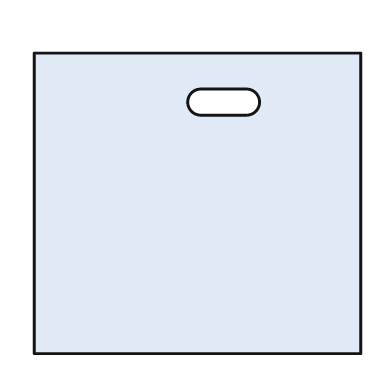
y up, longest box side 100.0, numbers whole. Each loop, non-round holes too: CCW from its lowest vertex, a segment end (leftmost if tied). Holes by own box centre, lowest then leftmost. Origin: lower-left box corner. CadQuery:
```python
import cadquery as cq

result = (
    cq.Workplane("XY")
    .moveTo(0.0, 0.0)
    .lineTo(100.0, 0.0)
    .lineTo(100.0, 92.0)
    .lineTo(0.0, 92.0)
    .close()
    .moveTo(51.0, 73.0)
    .lineTo(65.0, 73.0)
    .threePointArc((69.0, 77.0), (65.0, 81.0))
    .lineTo(51.0, 81.0)
    .threePointArc((47.0, 77.0), (51.0, 73.0))
    .close()
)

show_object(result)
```